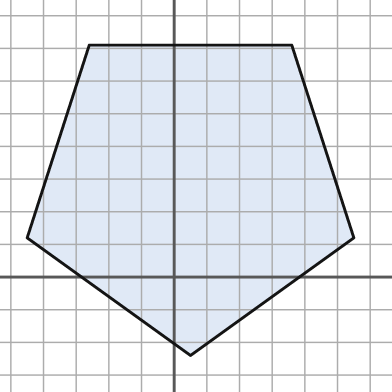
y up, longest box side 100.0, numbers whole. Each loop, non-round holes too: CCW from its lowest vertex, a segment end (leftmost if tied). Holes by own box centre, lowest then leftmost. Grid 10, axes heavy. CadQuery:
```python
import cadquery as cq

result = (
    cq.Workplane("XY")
    .moveTo(5.0, -24.0)
    .lineTo(55.0, 12.0)
    .lineTo(36.0, 71.0)
    .lineTo(-26.0, 71.0)
    .lineTo(-45.0, 12.0)
    .close()
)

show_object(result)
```